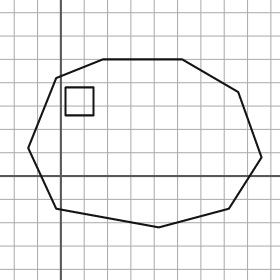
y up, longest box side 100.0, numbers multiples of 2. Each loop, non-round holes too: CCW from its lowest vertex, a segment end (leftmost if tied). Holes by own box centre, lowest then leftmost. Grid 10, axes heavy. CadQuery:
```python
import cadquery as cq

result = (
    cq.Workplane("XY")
    .moveTo(42.0, -22.0)
    .lineTo(72.0, -14.0)
    .lineTo(86.0, 8.0)
    .lineTo(76.0, 36.0)
    .lineTo(52.0, 50.0)
    .lineTo(18.0, 50.0)
    .lineTo(-2.0, 42.0)
    .lineTo(-14.0, 12.0)
    .lineTo(-2.0, -14.0)
    .close()
    .moveTo(2.0, 26.0)
    .lineTo(14.0, 26.0)
    .lineTo(14.0, 38.0)
    .lineTo(2.0, 38.0)
    .close()
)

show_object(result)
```